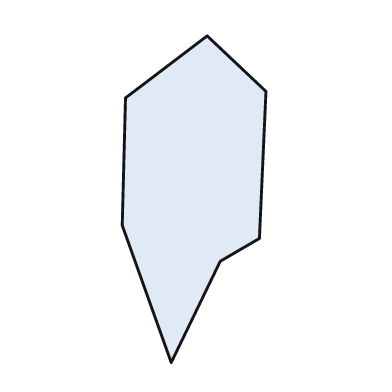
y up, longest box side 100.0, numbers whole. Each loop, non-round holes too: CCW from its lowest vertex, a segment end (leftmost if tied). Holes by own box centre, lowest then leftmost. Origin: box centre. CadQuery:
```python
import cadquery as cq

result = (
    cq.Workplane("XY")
    .moveTo(-7.0, -50.0)
    .lineTo(8.0, -19.0)
    .lineTo(20.0, -12.0)
    .lineTo(22.0, 33.0)
    .lineTo(4.0, 50.0)
    .lineTo(-21.0, 31.0)
    .lineTo(-22.0, -8.0)
    .close()
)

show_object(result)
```